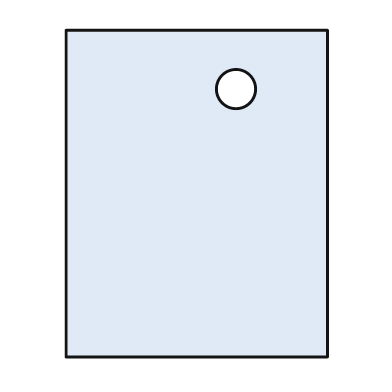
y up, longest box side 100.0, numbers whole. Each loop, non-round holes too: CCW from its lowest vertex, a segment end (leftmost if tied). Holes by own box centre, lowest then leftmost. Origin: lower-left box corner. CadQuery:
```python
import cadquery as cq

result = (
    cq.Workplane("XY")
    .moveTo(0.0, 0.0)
    .lineTo(80.0, 0.0)
    .lineTo(80.0, 100.0)
    .lineTo(0.0, 100.0)
    .close()
    .moveTo(52.0, 82.0)
    .circle(6.0)
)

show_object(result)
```